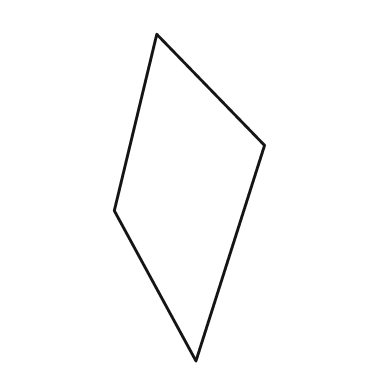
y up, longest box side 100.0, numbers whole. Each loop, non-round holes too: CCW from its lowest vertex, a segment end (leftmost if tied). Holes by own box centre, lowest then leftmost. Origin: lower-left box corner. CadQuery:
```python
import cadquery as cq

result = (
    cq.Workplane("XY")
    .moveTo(25.0, 0.0)
    .lineTo(46.0, 66.0)
    .lineTo(13.0, 100.0)
    .lineTo(0.0, 46.0)
    .close()
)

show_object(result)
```